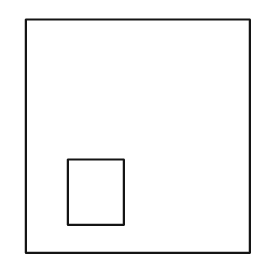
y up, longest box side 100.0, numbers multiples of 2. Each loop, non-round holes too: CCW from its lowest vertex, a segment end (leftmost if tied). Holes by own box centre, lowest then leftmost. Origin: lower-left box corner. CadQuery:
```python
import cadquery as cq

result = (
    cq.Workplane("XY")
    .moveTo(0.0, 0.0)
    .lineTo(96.0, 0.0)
    .lineTo(96.0, 100.0)
    .lineTo(0.0, 100.0)
    .close()
    .moveTo(18.0, 12.0)
    .lineTo(42.0, 12.0)
    .lineTo(42.0, 40.0)
    .lineTo(18.0, 40.0)
    .close()
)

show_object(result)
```